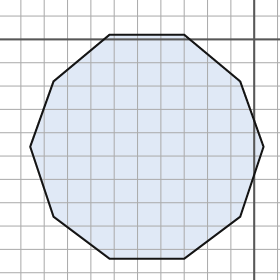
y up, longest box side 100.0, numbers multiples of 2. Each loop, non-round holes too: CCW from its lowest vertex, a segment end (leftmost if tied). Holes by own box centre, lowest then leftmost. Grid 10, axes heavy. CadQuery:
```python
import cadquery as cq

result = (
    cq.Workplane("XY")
    .moveTo(-62.0, -94.0)
    .lineTo(-30.0, -94.0)
    .lineTo(-6.0, -76.0)
    .lineTo(4.0, -46.0)
    .lineTo(-6.0, -18.0)
    .lineTo(-30.0, 2.0)
    .lineTo(-62.0, 2.0)
    .lineTo(-86.0, -18.0)
    .lineTo(-96.0, -46.0)
    .lineTo(-86.0, -76.0)
    .close()
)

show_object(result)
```